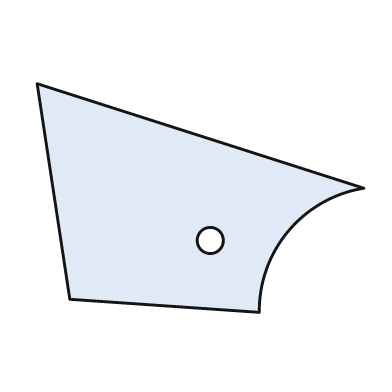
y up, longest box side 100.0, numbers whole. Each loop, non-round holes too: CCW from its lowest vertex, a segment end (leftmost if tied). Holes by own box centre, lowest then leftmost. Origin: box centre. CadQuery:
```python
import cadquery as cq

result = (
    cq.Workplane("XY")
    .moveTo(18.0, -35.0)
    .threePointArc((27.0, -10.0), (50.0, 3.0))
    .lineTo(-50.0, 35.0)
    .lineTo(-40.0, -31.0)
    .close()
    .moveTo(3.0, -13.0)
    .circle(4.0)
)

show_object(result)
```